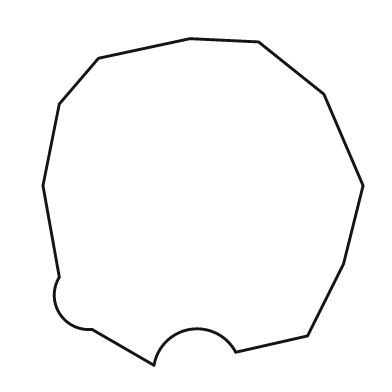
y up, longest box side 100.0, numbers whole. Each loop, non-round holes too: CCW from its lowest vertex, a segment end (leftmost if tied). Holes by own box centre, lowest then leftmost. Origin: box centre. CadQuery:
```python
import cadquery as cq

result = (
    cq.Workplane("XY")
    .moveTo(-15.0, -50.0)
    .threePointArc((-4.0, -39.0), (10.0, -46.0))
    .lineTo(32.0, -41.0)
    .lineTo(43.0, -19.0)
    .lineTo(49.0, 5.0)
    .lineTo(37.0, 33.0)
    .lineTo(17.0, 49.0)
    .lineTo(-4.0, 50.0)
    .lineTo(-32.0, 44.0)
    .lineTo(-44.0, 30.0)
    .lineTo(-49.0, 5.0)
    .lineTo(-44.0, -23.0)
    .threePointArc((-44.0, -34.0), (-34.0, -39.0))
    .close()
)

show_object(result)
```